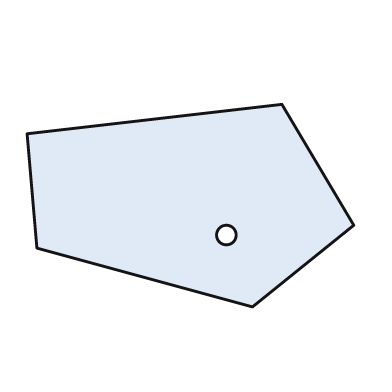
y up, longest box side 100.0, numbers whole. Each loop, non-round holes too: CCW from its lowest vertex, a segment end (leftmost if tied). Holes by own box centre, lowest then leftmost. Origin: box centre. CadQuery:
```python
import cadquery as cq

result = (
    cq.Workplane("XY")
    .moveTo(19.0, -31.0)
    .lineTo(50.0, -6.0)
    .lineTo(28.0, 31.0)
    .lineTo(-50.0, 22.0)
    .lineTo(-47.0, -13.0)
    .close()
    .moveTo(11.0, -9.0)
    .circle(3.0)
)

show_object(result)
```